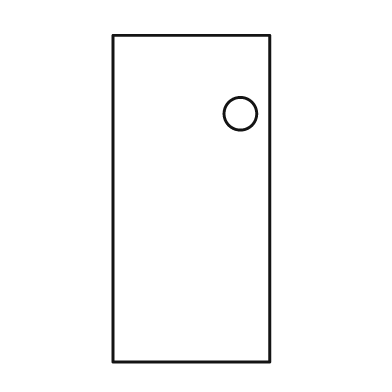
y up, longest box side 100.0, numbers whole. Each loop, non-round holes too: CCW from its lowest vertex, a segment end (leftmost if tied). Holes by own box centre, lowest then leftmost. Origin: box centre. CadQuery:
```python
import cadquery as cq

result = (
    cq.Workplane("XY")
    .moveTo(-24.0, -50.0)
    .lineTo(24.0, -50.0)
    .lineTo(24.0, 50.0)
    .lineTo(-24.0, 50.0)
    .close()
    .moveTo(15.0, 26.0)
    .circle(5.0)
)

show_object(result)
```